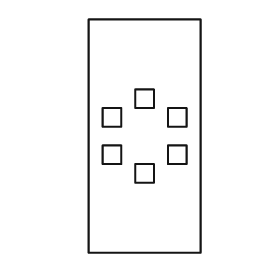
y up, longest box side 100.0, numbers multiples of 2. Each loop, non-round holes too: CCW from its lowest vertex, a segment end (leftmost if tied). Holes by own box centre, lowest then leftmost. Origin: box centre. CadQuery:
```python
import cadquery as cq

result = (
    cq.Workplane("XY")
    .moveTo(-24.0, -50.0)
    .lineTo(24.0, -50.0)
    .lineTo(24.0, 50.0)
    .lineTo(-24.0, 50.0)
    .close()
    .moveTo(-4.0, -20.0)
    .lineTo(4.0, -20.0)
    .lineTo(4.0, -12.0)
    .lineTo(-4.0, -12.0)
    .close()
    .moveTo(-18.0, -12.0)
    .lineTo(-10.0, -12.0)
    .lineTo(-10.0, -4.0)
    .lineTo(-18.0, -4.0)
    .close()
    .moveTo(10.0, -12.0)
    .lineTo(18.0, -12.0)
    .lineTo(18.0, -4.0)
    .lineTo(10.0, -4.0)
    .close()
    .moveTo(-18.0, 4.0)
    .lineTo(-10.0, 4.0)
    .lineTo(-10.0, 12.0)
    .lineTo(-18.0, 12.0)
    .close()
    .moveTo(10.0, 4.0)
    .lineTo(18.0, 4.0)
    .lineTo(18.0, 12.0)
    .lineTo(10.0, 12.0)
    .close()
    .moveTo(-4.0, 12.0)
    .lineTo(4.0, 12.0)
    .lineTo(4.0, 20.0)
    .lineTo(-4.0, 20.0)
    .close()
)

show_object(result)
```